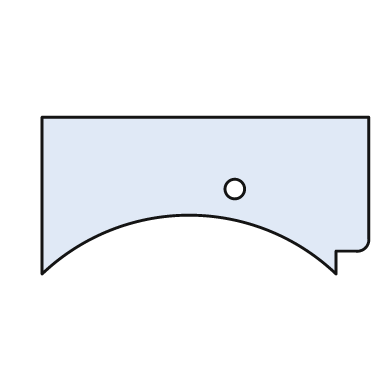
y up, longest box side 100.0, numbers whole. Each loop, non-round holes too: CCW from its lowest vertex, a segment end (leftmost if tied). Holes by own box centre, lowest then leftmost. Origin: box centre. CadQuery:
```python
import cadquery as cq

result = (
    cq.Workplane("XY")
    .moveTo(-50.0, -24.0)
    .threePointArc((-5.0, -6.0), (40.0, -24.0))
    .lineTo(40.0, -17.0)
    .lineTo(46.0, -17.0)
    .threePointArc((49.0, -16.0), (50.0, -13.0))
    .lineTo(50.0, 24.0)
    .lineTo(-50.0, 24.0)
    .close()
    .moveTo(9.0, 2.0)
    .circle(3.0)
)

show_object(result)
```